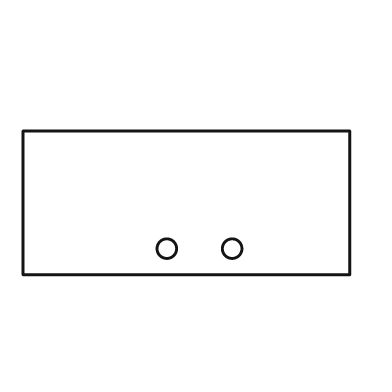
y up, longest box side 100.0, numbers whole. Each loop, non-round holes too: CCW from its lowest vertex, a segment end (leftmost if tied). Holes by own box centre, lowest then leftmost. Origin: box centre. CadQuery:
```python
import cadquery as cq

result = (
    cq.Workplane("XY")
    .moveTo(-50.0, -22.0)
    .lineTo(50.0, -22.0)
    .lineTo(50.0, 22.0)
    .lineTo(-50.0, 22.0)
    .close()
    .moveTo(-6.0, -14.0)
    .circle(3.0)
    .moveTo(14.0, -14.0)
    .circle(3.0)
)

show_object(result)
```